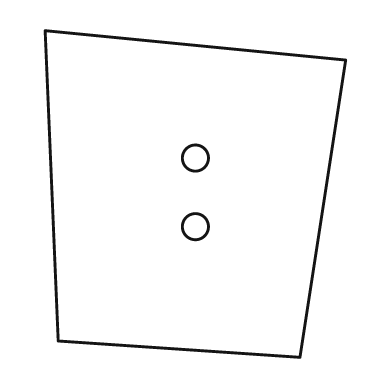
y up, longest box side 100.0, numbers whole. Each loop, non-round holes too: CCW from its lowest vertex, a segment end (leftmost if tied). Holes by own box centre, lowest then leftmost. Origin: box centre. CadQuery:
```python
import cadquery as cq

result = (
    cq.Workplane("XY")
    .moveTo(32.0, -50.0)
    .lineTo(46.0, 41.0)
    .lineTo(-46.0, 50.0)
    .lineTo(-42.0, -45.0)
    .close()
    .moveTo(0.0, -10.0)
    .circle(4.0)
    .moveTo(0.0, 11.0)
    .circle(4.0)
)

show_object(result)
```